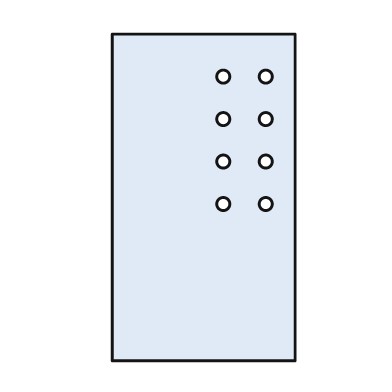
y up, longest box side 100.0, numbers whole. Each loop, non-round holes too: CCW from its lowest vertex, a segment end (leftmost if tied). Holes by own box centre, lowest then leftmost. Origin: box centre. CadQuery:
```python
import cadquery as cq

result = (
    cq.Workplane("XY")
    .moveTo(-28.0, -50.0)
    .lineTo(28.0, -50.0)
    .lineTo(28.0, 50.0)
    .lineTo(-28.0, 50.0)
    .close()
    .moveTo(6.0, -2.0)
    .circle(2.0)
    .moveTo(19.0, -2.0)
    .circle(2.0)
    .moveTo(6.0, 11.0)
    .circle(2.0)
    .moveTo(19.0, 11.0)
    .circle(2.0)
    .moveTo(6.0, 24.0)
    .circle(2.0)
    .moveTo(19.0, 24.0)
    .circle(2.0)
    .moveTo(6.0, 37.0)
    .circle(2.0)
    .moveTo(19.0, 37.0)
    .circle(2.0)
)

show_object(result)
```